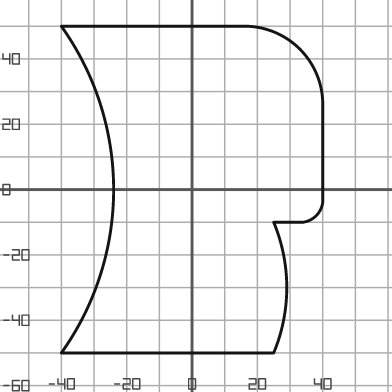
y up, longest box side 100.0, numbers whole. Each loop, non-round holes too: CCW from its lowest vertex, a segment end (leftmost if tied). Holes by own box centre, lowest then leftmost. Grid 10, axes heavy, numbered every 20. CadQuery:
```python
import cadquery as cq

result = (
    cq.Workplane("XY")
    .moveTo(-40.0, -50.0)
    .lineTo(25.0, -50.0)
    .threePointArc((29.0, -30.0), (25.0, -10.0))
    .lineTo(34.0, -10.0)
    .threePointArc((38.0, -8.0), (40.0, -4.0))
    .lineTo(40.0, 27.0)
    .threePointArc((33.0, 43.0), (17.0, 50.0))
    .lineTo(-40.0, 50.0)
    .threePointArc((-24.0, 0.0), (-40.0, -50.0))
    .close()
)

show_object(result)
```